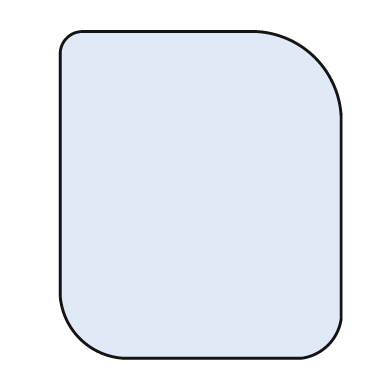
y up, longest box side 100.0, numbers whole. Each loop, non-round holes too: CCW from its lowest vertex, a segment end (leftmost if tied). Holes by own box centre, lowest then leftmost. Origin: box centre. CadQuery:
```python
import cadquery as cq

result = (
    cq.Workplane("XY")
    .moveTo(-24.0, -50.0)
    .lineTo(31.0, -50.0)
    .threePointArc((39.0, -46.0), (43.0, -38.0))
    .lineTo(43.0, 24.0)
    .threePointArc((35.0, 42.0), (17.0, 50.0))
    .lineTo(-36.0, 50.0)
    .threePointArc((-41.0, 48.0), (-43.0, 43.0))
    .lineTo(-43.0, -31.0)
    .threePointArc((-37.0, -44.0), (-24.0, -50.0))
    .close()
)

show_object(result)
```